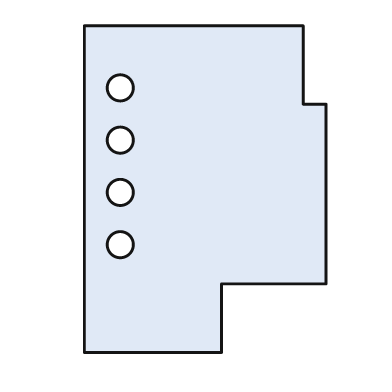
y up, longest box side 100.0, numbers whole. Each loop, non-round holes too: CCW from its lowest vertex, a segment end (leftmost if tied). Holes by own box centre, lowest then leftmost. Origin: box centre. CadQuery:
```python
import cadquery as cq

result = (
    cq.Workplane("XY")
    .moveTo(-37.0, -50.0)
    .lineTo(5.0, -50.0)
    .lineTo(5.0, -29.0)
    .lineTo(37.0, -29.0)
    .lineTo(37.0, 26.0)
    .lineTo(30.0, 26.0)
    .lineTo(30.0, 50.0)
    .lineTo(-37.0, 50.0)
    .close()
    .moveTo(-26.0, -17.0)
    .circle(4.0)
    .moveTo(-26.0, -1.0)
    .circle(4.0)
    .moveTo(-26.0, 15.0)
    .circle(4.0)
    .moveTo(-26.0, 31.0)
    .circle(4.0)
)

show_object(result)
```